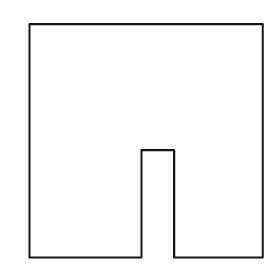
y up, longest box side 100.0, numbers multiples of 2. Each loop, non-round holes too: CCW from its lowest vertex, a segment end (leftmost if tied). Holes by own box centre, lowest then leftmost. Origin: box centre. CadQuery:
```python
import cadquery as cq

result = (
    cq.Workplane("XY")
    .moveTo(-50.0, -50.0)
    .lineTo(-2.0, -50.0)
    .lineTo(-2.0, -4.0)
    .lineTo(12.0, -4.0)
    .lineTo(12.0, -50.0)
    .lineTo(50.0, -50.0)
    .lineTo(50.0, 50.0)
    .lineTo(-50.0, 50.0)
    .close()
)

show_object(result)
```